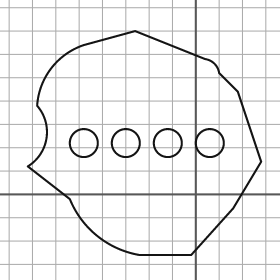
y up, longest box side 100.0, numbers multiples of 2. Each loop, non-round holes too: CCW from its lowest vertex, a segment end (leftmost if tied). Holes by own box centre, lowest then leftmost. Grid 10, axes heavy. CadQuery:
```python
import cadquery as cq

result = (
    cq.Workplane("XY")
    .moveTo(-24.0, -26.0)
    .lineTo(-2.0, -26.0)
    .lineTo(16.0, -6.0)
    .lineTo(28.0, 14.0)
    .lineTo(18.0, 44.0)
    .lineTo(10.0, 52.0)
    .threePointArc((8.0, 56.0), (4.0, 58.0))
    .lineTo(-26.0, 70.0)
    .lineTo(-48.0, 64.0)
    .threePointArc((-62.0, 54.0), (-68.0, 38.0))
    .threePointArc((-64.0, 24.0), (-72.0, 12.0))
    .lineTo(-54.0, -2.0)
    .threePointArc((-42.0, -18.0), (-24.0, -26.0))
    .close()
    .moveTo(-48.0, 22.0)
    .circle(6.0)
    .moveTo(-30.0, 22.0)
    .circle(6.0)
    .moveTo(-12.0, 22.0)
    .circle(6.0)
    .moveTo(6.0, 22.0)
    .circle(6.0)
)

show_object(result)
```